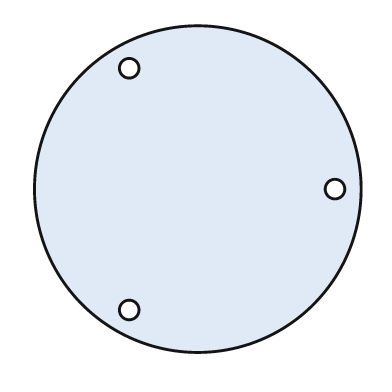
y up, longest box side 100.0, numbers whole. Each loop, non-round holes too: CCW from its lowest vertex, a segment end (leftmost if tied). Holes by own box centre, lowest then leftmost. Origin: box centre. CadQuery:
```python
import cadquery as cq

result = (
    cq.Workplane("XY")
    .moveTo(0.0, 0.0)
    .circle(50.0)
    .moveTo(-21.0, -37.0)
    .circle(3.0)
    .moveTo(42.0, 0.0)
    .circle(3.0)
    .moveTo(-21.0, 37.0)
    .circle(3.0)
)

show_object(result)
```